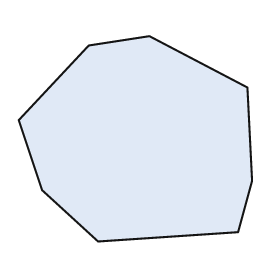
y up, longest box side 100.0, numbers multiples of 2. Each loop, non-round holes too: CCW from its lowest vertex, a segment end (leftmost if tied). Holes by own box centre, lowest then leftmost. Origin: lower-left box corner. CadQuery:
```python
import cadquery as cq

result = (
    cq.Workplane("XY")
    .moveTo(34.0, 0.0)
    .lineTo(94.0, 4.0)
    .lineTo(100.0, 26.0)
    .lineTo(98.0, 66.0)
    .lineTo(56.0, 88.0)
    .lineTo(30.0, 84.0)
    .lineTo(0.0, 52.0)
    .lineTo(10.0, 22.0)
    .close()
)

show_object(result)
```